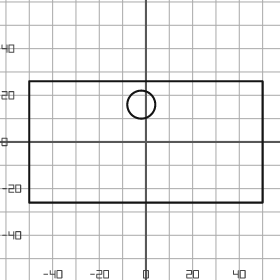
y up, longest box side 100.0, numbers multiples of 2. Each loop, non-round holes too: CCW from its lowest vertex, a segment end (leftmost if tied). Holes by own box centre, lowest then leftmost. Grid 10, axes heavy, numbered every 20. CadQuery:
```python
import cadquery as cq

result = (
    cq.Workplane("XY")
    .moveTo(-50.0, -26.0)
    .lineTo(50.0, -26.0)
    .lineTo(50.0, 26.0)
    .lineTo(-50.0, 26.0)
    .close()
    .moveTo(-2.0, 16.0)
    .circle(6.0)
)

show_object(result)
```